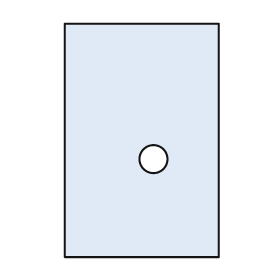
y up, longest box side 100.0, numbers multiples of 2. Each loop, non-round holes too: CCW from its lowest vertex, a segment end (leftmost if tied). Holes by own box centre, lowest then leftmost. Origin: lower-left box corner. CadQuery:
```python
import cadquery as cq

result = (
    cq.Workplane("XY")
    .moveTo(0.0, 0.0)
    .lineTo(66.0, 0.0)
    .lineTo(66.0, 100.0)
    .lineTo(0.0, 100.0)
    .close()
    .moveTo(38.0, 42.0)
    .circle(6.0)
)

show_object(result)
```